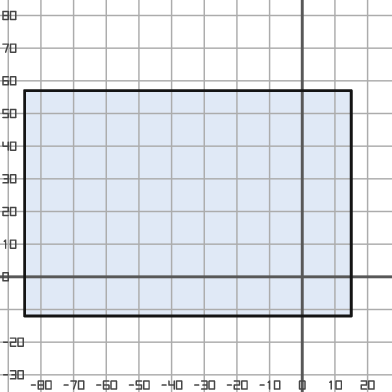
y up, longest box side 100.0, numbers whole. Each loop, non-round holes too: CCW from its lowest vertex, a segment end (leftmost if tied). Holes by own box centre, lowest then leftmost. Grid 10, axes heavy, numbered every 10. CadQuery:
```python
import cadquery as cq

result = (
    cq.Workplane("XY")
    .moveTo(-85.0, -12.0)
    .lineTo(15.0, -12.0)
    .lineTo(15.0, 57.0)
    .lineTo(-85.0, 57.0)
    .close()
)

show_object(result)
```